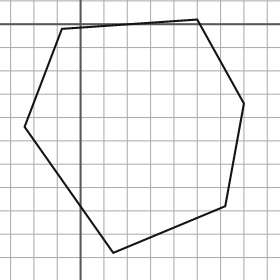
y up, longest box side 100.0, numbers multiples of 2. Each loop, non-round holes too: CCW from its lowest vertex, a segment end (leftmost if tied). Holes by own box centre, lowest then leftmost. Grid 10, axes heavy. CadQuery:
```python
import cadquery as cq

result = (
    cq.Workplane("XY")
    .moveTo(14.0, -98.0)
    .lineTo(62.0, -78.0)
    .lineTo(70.0, -34.0)
    .lineTo(50.0, 2.0)
    .lineTo(-8.0, -2.0)
    .lineTo(-24.0, -44.0)
    .close()
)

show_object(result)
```